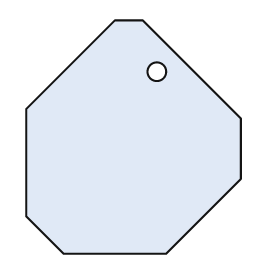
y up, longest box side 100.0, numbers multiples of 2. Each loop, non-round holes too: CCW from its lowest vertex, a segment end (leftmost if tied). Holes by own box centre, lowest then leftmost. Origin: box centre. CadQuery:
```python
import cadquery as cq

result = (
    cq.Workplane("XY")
    .moveTo(-30.0, -50.0)
    .lineTo(14.0, -50.0)
    .lineTo(46.0, -18.0)
    .lineTo(46.0, 8.0)
    .lineTo(4.0, 50.0)
    .lineTo(-8.0, 50.0)
    .lineTo(-46.0, 12.0)
    .lineTo(-46.0, -34.0)
    .close()
    .moveTo(10.0, 28.0)
    .circle(4.0)
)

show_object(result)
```